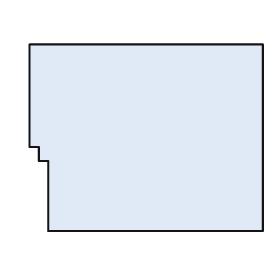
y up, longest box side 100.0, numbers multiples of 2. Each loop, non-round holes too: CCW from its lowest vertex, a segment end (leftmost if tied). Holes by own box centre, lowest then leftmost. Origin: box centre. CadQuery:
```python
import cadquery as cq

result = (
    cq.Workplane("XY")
    .moveTo(-42.0, -40.0)
    .lineTo(50.0, -40.0)
    .lineTo(50.0, 40.0)
    .lineTo(-50.0, 40.0)
    .lineTo(-50.0, -4.0)
    .lineTo(-46.0, -4.0)
    .lineTo(-46.0, -10.0)
    .lineTo(-42.0, -10.0)
    .close()
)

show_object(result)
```